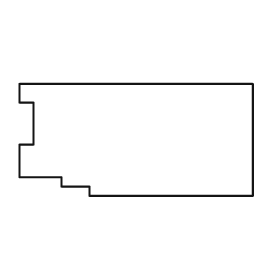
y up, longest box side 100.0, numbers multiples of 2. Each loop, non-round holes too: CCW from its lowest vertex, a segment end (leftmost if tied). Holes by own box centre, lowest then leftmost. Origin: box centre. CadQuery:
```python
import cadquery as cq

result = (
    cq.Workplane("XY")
    .moveTo(-20.0, -24.0)
    .lineTo(50.0, -24.0)
    .lineTo(50.0, 24.0)
    .lineTo(-50.0, 24.0)
    .lineTo(-50.0, 16.0)
    .lineTo(-44.0, 16.0)
    .lineTo(-44.0, -2.0)
    .lineTo(-50.0, -2.0)
    .lineTo(-50.0, -16.0)
    .lineTo(-32.0, -16.0)
    .lineTo(-32.0, -20.0)
    .lineTo(-20.0, -20.0)
    .close()
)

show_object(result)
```